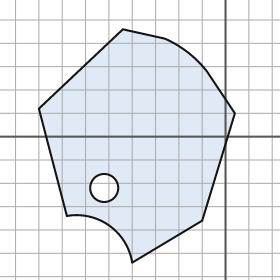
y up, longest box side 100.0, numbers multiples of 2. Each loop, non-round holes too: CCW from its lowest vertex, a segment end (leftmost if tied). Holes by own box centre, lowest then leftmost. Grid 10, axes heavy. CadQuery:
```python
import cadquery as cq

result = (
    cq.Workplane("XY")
    .moveTo(-40.0, -54.0)
    .lineTo(-10.0, -36.0)
    .lineTo(4.0, 10.0)
    .lineTo(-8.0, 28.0)
    .threePointArc((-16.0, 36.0), (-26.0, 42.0))
    .lineTo(-44.0, 46.0)
    .lineTo(-80.0, 12.0)
    .lineTo(-68.0, -34.0)
    .threePointArc((-50.0, -38.0), (-40.0, -54.0))
    .close()
    .moveTo(-52.0, -22.0)
    .circle(6.0)
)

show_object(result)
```